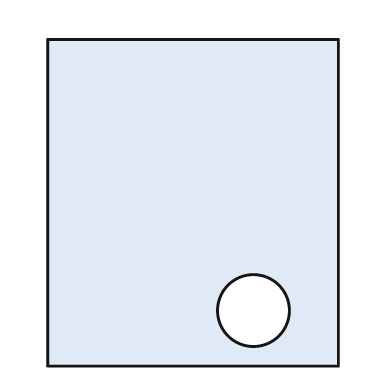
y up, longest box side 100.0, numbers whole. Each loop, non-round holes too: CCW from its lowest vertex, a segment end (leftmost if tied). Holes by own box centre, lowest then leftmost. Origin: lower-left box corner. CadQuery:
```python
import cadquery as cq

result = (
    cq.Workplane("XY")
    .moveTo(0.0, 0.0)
    .lineTo(89.0, 0.0)
    .lineTo(89.0, 100.0)
    .lineTo(0.0, 100.0)
    .close()
    .moveTo(63.0, 17.0)
    .circle(11.0)
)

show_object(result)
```